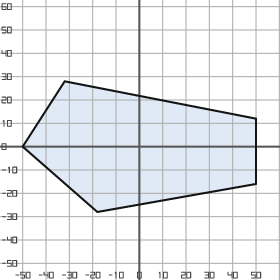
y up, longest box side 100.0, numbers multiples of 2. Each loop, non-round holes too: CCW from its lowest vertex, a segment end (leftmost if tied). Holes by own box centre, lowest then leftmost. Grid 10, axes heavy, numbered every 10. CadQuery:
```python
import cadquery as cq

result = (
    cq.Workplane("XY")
    .moveTo(-18.0, -28.0)
    .lineTo(50.0, -16.0)
    .lineTo(50.0, 12.0)
    .lineTo(-32.0, 28.0)
    .lineTo(-50.0, 0.0)
    .close()
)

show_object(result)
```